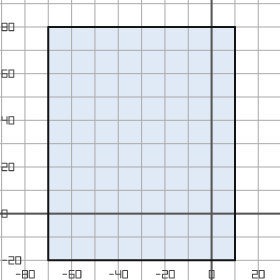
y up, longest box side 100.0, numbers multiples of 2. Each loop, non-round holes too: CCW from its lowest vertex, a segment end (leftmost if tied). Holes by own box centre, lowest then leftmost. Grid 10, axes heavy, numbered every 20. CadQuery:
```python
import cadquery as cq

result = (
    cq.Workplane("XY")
    .moveTo(-70.0, -20.0)
    .lineTo(10.0, -20.0)
    .lineTo(10.0, 80.0)
    .lineTo(-70.0, 80.0)
    .close()
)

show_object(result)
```